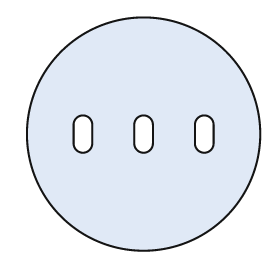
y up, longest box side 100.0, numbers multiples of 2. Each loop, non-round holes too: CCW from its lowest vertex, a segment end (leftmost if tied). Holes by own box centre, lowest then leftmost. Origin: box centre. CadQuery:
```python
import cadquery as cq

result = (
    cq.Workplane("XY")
    .moveTo(0.0, 0.0)
    .circle(50.0)
    .moveTo(-30.0, -4.0)
    .threePointArc((-26.0, -8.0), (-22.0, -4.0))
    .lineTo(-22.0, 4.0)
    .threePointArc((-26.0, 8.0), (-30.0, 4.0))
    .close()
    .moveTo(-4.0, -4.0)
    .threePointArc((0.0, -8.0), (4.0, -4.0))
    .lineTo(4.0, 4.0)
    .threePointArc((0.0, 8.0), (-4.0, 4.0))
    .close()
    .moveTo(22.0, -4.0)
    .threePointArc((26.0, -8.0), (30.0, -4.0))
    .lineTo(30.0, 4.0)
    .threePointArc((26.0, 8.0), (22.0, 4.0))
    .close()
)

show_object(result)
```